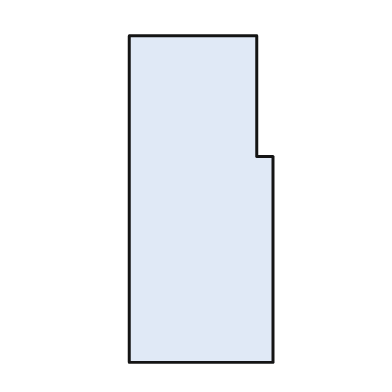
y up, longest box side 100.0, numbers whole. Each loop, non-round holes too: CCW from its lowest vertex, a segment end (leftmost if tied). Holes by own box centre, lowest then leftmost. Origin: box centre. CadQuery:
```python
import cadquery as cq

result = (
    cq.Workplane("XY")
    .moveTo(-22.0, -50.0)
    .lineTo(22.0, -50.0)
    .lineTo(22.0, 13.0)
    .lineTo(17.0, 13.0)
    .lineTo(17.0, 50.0)
    .lineTo(-22.0, 50.0)
    .close()
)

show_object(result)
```